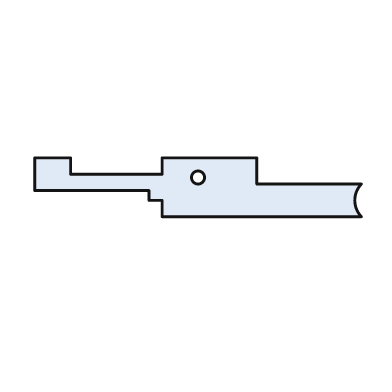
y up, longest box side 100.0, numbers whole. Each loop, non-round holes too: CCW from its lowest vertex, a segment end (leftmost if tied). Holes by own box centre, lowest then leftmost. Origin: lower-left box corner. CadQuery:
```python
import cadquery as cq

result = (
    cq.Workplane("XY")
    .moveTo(39.0, 0.0)
    .lineTo(100.0, 0.0)
    .threePointArc((98.0, 5.0), (100.0, 10.0))
    .lineTo(68.0, 10.0)
    .lineTo(68.0, 18.0)
    .lineTo(39.0, 18.0)
    .lineTo(39.0, 13.0)
    .lineTo(11.0, 13.0)
    .lineTo(11.0, 18.0)
    .lineTo(0.0, 18.0)
    .lineTo(0.0, 8.0)
    .lineTo(35.0, 8.0)
    .lineTo(35.0, 5.0)
    .lineTo(39.0, 5.0)
    .close()
    .moveTo(50.0, 12.0)
    .circle(2.0)
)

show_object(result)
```